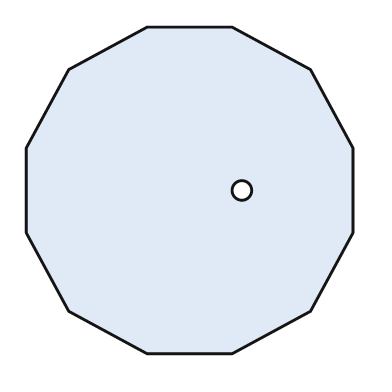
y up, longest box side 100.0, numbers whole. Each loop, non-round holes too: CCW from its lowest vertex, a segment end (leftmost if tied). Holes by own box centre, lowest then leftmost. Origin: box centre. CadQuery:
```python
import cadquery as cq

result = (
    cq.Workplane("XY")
    .moveTo(-13.0, -50.0)
    .lineTo(13.0, -50.0)
    .lineTo(37.0, -37.0)
    .lineTo(50.0, -13.0)
    .lineTo(50.0, 13.0)
    .lineTo(37.0, 37.0)
    .lineTo(13.0, 50.0)
    .lineTo(-13.0, 50.0)
    .lineTo(-37.0, 37.0)
    .lineTo(-50.0, 13.0)
    .lineTo(-50.0, -13.0)
    .lineTo(-37.0, -37.0)
    .close()
    .moveTo(16.0, 0.0)
    .circle(3.0)
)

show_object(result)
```